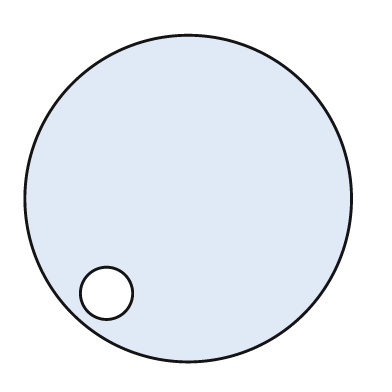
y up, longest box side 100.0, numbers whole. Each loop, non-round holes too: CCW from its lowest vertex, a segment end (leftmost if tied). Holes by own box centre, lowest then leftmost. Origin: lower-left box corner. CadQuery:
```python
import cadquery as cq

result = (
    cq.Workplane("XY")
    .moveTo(50.0, 50.0)
    .circle(50.0)
    .moveTo(25.0, 21.0)
    .circle(8.0)
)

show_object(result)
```